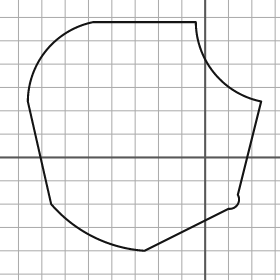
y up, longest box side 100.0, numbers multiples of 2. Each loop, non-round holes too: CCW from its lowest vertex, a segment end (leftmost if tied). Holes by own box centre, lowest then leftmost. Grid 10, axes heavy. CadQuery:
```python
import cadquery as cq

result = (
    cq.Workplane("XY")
    .moveTo(-26.0, -40.0)
    .lineTo(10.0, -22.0)
    .threePointArc((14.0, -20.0), (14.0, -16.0))
    .lineTo(24.0, 24.0)
    .threePointArc((4.0, 36.0), (-4.0, 58.0))
    .lineTo(-48.0, 58.0)
    .threePointArc((-68.0, 46.0), (-76.0, 24.0))
    .lineTo(-66.0, -20.0)
    .threePointArc((-48.0, -34.0), (-26.0, -40.0))
    .close()
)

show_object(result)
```